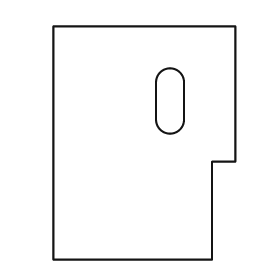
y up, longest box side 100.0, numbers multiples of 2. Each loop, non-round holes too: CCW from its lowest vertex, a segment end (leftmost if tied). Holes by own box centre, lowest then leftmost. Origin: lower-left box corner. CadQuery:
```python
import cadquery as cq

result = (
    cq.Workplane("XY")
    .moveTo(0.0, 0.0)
    .lineTo(68.0, 0.0)
    .lineTo(68.0, 42.0)
    .lineTo(78.0, 42.0)
    .lineTo(78.0, 100.0)
    .lineTo(0.0, 100.0)
    .close()
    .moveTo(44.0, 60.0)
    .threePointArc((50.0, 54.0), (56.0, 60.0))
    .lineTo(56.0, 76.0)
    .threePointArc((50.0, 82.0), (44.0, 76.0))
    .close()
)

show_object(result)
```